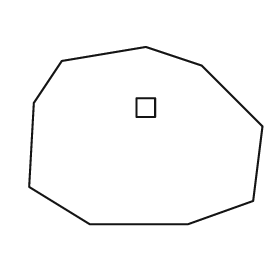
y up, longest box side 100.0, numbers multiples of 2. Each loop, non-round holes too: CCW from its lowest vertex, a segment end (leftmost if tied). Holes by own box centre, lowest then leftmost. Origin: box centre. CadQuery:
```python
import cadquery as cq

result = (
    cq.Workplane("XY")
    .moveTo(-24.0, -38.0)
    .lineTo(18.0, -38.0)
    .lineTo(46.0, -28.0)
    .lineTo(50.0, 4.0)
    .lineTo(24.0, 30.0)
    .lineTo(0.0, 38.0)
    .lineTo(-36.0, 32.0)
    .lineTo(-48.0, 14.0)
    .lineTo(-50.0, -22.0)
    .close()
    .moveTo(-4.0, 8.0)
    .lineTo(4.0, 8.0)
    .lineTo(4.0, 16.0)
    .lineTo(-4.0, 16.0)
    .close()
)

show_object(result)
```